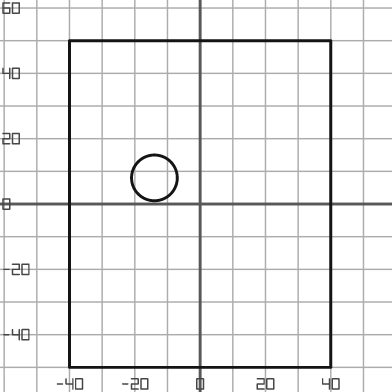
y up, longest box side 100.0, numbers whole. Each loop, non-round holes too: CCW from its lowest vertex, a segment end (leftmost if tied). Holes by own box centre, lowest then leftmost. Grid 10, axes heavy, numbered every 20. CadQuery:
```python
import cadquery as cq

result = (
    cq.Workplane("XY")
    .moveTo(-40.0, -50.0)
    .lineTo(40.0, -50.0)
    .lineTo(40.0, 50.0)
    .lineTo(-40.0, 50.0)
    .close()
    .moveTo(-14.0, 8.0)
    .circle(7.0)
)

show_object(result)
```